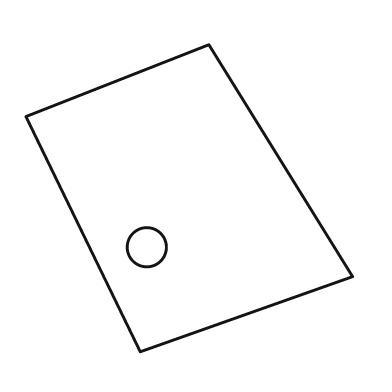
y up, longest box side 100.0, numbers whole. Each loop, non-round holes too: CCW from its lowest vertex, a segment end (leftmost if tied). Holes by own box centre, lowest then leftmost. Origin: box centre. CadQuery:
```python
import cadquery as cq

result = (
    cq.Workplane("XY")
    .moveTo(-15.0, -47.0)
    .lineTo(50.0, -24.0)
    .lineTo(6.0, 47.0)
    .lineTo(-50.0, 25.0)
    .close()
    .moveTo(-13.0, -15.0)
    .circle(6.0)
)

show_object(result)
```